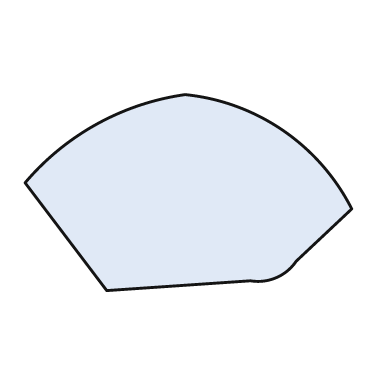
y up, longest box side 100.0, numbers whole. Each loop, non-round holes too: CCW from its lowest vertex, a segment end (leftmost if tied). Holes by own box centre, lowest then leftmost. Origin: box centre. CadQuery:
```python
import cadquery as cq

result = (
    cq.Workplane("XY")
    .moveTo(-25.0, -30.0)
    .lineTo(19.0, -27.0)
    .threePointArc((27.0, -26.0), (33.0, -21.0))
    .lineTo(50.0, -5.0)
    .threePointArc((29.0, 19.0), (-1.0, 30.0))
    .threePointArc((-28.0, 21.0), (-50.0, 3.0))
    .close()
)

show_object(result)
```